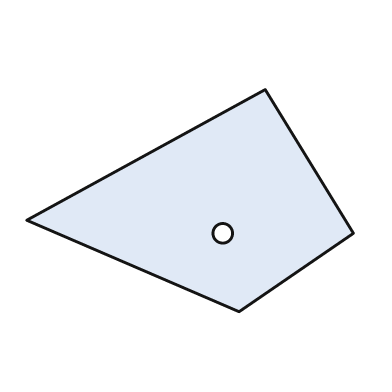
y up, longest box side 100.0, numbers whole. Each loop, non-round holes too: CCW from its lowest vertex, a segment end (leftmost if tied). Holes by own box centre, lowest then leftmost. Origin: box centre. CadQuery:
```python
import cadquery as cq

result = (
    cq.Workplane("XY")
    .moveTo(15.0, -34.0)
    .lineTo(50.0, -10.0)
    .lineTo(23.0, 34.0)
    .lineTo(-50.0, -6.0)
    .close()
    .moveTo(10.0, -10.0)
    .circle(3.0)
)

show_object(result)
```